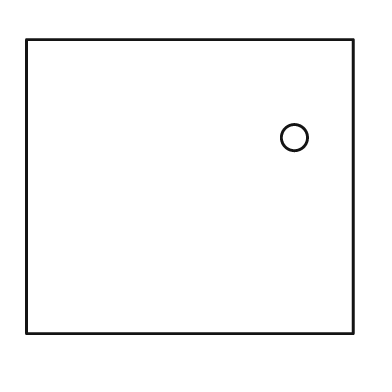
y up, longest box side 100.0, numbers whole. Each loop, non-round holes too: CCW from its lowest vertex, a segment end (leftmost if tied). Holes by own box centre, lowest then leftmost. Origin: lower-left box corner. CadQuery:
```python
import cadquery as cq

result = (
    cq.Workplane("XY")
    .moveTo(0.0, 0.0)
    .lineTo(100.0, 0.0)
    .lineTo(100.0, 90.0)
    .lineTo(0.0, 90.0)
    .close()
    .moveTo(82.0, 60.0)
    .circle(4.0)
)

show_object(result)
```